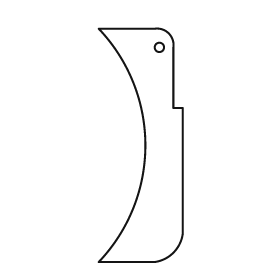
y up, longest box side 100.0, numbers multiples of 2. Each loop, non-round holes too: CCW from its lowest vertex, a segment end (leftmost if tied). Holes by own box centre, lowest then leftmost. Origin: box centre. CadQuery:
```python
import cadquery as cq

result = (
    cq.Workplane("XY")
    .moveTo(-18.0, -50.0)
    .lineTo(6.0, -50.0)
    .threePointArc((14.0, -46.0), (18.0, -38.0))
    .lineTo(18.0, 16.0)
    .lineTo(14.0, 16.0)
    .lineTo(14.0, 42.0)
    .threePointArc((12.0, 48.0), (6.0, 50.0))
    .lineTo(-18.0, 50.0)
    .threePointArc((2.0, 0.0), (-18.0, -50.0))
    .close()
    .moveTo(8.0, 42.0)
    .circle(2.0)
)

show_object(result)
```